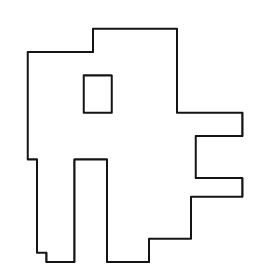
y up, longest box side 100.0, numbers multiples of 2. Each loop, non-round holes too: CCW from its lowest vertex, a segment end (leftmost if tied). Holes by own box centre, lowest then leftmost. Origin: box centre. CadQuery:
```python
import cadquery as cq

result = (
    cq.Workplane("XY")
    .moveTo(-38.0, -50.0)
    .lineTo(-26.0, -50.0)
    .lineTo(-26.0, -6.0)
    .lineTo(-12.0, -6.0)
    .lineTo(-12.0, -50.0)
    .lineTo(6.0, -50.0)
    .lineTo(6.0, -40.0)
    .lineTo(24.0, -40.0)
    .lineTo(24.0, -22.0)
    .lineTo(46.0, -22.0)
    .lineTo(46.0, -14.0)
    .lineTo(26.0, -14.0)
    .lineTo(26.0, 4.0)
    .lineTo(46.0, 4.0)
    .lineTo(46.0, 14.0)
    .lineTo(18.0, 14.0)
    .lineTo(18.0, 50.0)
    .lineTo(-18.0, 50.0)
    .lineTo(-18.0, 40.0)
    .lineTo(-46.0, 40.0)
    .lineTo(-46.0, -6.0)
    .lineTo(-42.0, -6.0)
    .lineTo(-42.0, -46.0)
    .lineTo(-38.0, -46.0)
    .close()
    .moveTo(-22.0, 14.0)
    .lineTo(-10.0, 14.0)
    .lineTo(-10.0, 30.0)
    .lineTo(-22.0, 30.0)
    .close()
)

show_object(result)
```